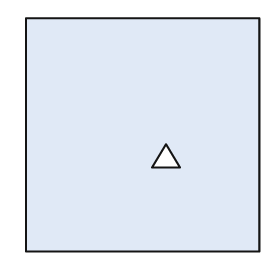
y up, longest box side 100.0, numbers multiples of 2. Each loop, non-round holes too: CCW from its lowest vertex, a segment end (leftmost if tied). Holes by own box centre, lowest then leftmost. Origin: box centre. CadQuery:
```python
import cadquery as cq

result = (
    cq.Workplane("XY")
    .moveTo(-50.0, -50.0)
    .lineTo(50.0, -50.0)
    .lineTo(50.0, 50.0)
    .lineTo(-50.0, 50.0)
    .close()
    .moveTo(4.0, -14.0)
    .lineTo(16.0, -14.0)
    .lineTo(10.0, -4.0)
    .close()
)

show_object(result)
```